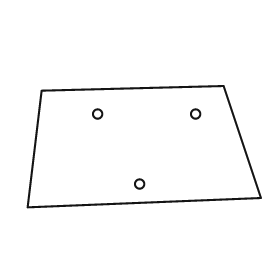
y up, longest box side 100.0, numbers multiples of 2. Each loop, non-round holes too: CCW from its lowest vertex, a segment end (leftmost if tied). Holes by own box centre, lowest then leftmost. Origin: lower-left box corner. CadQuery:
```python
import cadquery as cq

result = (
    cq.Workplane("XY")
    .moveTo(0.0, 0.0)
    .lineTo(100.0, 4.0)
    .lineTo(84.0, 52.0)
    .lineTo(6.0, 50.0)
    .close()
    .moveTo(48.0, 10.0)
    .circle(2.0)
    .moveTo(30.0, 40.0)
    .circle(2.0)
    .moveTo(72.0, 40.0)
    .circle(2.0)
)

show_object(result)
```